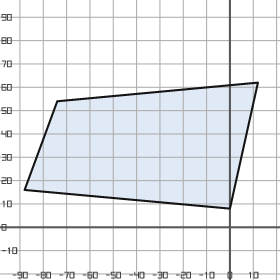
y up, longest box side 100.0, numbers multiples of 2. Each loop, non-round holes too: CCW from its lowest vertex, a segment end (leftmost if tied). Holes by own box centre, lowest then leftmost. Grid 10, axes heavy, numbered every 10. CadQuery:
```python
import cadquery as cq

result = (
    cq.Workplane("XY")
    .moveTo(0.0, 8.0)
    .lineTo(12.0, 62.0)
    .lineTo(-74.0, 54.0)
    .lineTo(-88.0, 16.0)
    .close()
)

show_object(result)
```